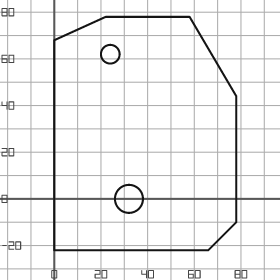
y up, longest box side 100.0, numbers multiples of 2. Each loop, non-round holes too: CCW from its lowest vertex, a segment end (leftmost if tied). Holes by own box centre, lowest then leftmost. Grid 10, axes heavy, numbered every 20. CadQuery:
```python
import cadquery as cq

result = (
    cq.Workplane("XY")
    .moveTo(0.0, -22.0)
    .lineTo(66.0, -22.0)
    .lineTo(78.0, -10.0)
    .lineTo(78.0, 44.0)
    .lineTo(58.0, 78.0)
    .lineTo(22.0, 78.0)
    .lineTo(0.0, 68.0)
    .close()
    .moveTo(32.0, 0.0)
    .circle(6.0)
    .moveTo(24.0, 62.0)
    .circle(4.0)
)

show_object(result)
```